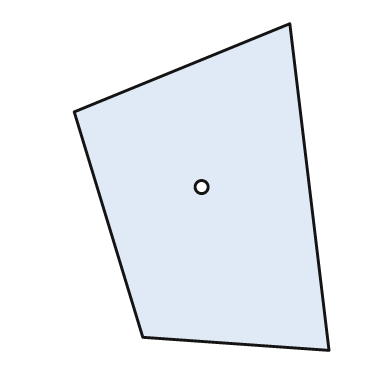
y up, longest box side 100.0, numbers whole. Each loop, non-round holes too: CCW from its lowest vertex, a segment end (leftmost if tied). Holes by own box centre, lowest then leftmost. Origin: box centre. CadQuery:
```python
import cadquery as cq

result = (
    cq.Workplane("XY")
    .moveTo(39.0, -50.0)
    .lineTo(27.0, 50.0)
    .lineTo(-39.0, 23.0)
    .lineTo(-18.0, -46.0)
    .close()
    .moveTo(0.0, 0.0)
    .circle(2.0)
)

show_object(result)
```